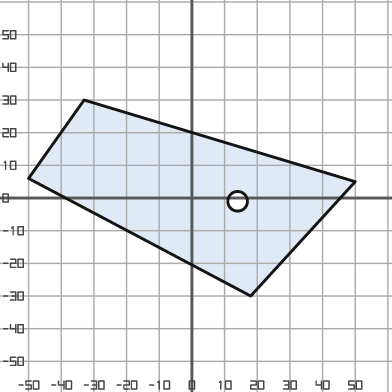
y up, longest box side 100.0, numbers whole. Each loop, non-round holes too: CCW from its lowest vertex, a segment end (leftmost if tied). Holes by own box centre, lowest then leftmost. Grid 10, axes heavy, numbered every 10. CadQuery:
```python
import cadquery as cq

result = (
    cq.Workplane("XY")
    .moveTo(18.0, -30.0)
    .lineTo(50.0, 5.0)
    .lineTo(-33.0, 30.0)
    .lineTo(-50.0, 6.0)
    .close()
    .moveTo(14.0, -1.0)
    .circle(3.0)
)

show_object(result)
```